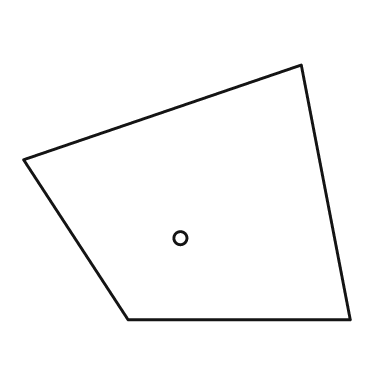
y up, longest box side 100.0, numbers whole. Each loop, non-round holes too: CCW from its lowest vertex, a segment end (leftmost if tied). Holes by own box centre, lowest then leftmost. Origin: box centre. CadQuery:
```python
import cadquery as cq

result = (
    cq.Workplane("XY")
    .moveTo(-18.0, -39.0)
    .lineTo(50.0, -39.0)
    .lineTo(35.0, 39.0)
    .lineTo(-50.0, 10.0)
    .close()
    .moveTo(-2.0, -14.0)
    .circle(2.0)
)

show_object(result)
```